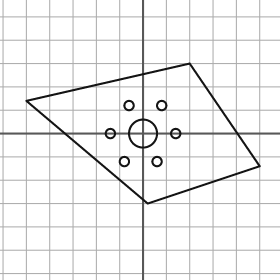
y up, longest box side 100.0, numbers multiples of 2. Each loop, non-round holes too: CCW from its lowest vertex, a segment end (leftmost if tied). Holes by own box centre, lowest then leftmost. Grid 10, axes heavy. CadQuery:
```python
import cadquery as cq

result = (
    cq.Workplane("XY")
    .moveTo(2.0, -30.0)
    .lineTo(50.0, -14.0)
    .lineTo(20.0, 30.0)
    .lineTo(-50.0, 14.0)
    .close()
    .moveTo(-8.0, -12.0)
    .circle(2.0)
    .moveTo(6.0, -12.0)
    .circle(2.0)
    .moveTo(-14.0, 0.0)
    .circle(2.0)
    .moveTo(0.0, 0.0)
    .circle(6.0)
    .moveTo(14.0, 0.0)
    .circle(2.0)
    .moveTo(-6.0, 12.0)
    .circle(2.0)
    .moveTo(8.0, 12.0)
    .circle(2.0)
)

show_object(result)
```